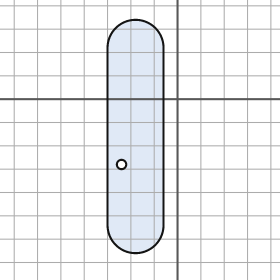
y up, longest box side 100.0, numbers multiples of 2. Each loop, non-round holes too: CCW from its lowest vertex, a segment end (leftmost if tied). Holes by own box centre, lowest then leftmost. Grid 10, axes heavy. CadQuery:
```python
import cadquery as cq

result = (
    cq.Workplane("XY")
    .moveTo(-30.0, -54.0)
    .threePointArc((-18.0, -66.0), (-6.0, -54.0))
    .lineTo(-6.0, 22.0)
    .threePointArc((-18.0, 34.0), (-30.0, 22.0))
    .close()
    .moveTo(-24.0, -28.0)
    .circle(2.0)
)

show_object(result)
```